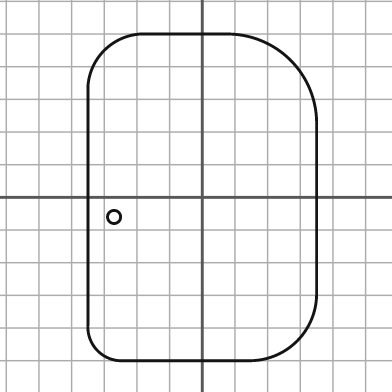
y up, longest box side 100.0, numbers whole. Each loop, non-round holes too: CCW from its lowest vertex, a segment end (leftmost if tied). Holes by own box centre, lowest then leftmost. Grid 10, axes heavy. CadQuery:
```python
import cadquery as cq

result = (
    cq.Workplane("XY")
    .moveTo(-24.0, -50.0)
    .lineTo(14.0, -50.0)
    .threePointArc((29.0, -44.0), (35.0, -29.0))
    .lineTo(35.0, 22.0)
    .threePointArc((27.0, 42.0), (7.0, 50.0))
    .lineTo(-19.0, 50.0)
    .threePointArc((-30.0, 45.0), (-35.0, 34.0))
    .lineTo(-35.0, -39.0)
    .threePointArc((-32.0, -47.0), (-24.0, -50.0))
    .close()
    .moveTo(-27.0, -6.0)
    .circle(2.0)
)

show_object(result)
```